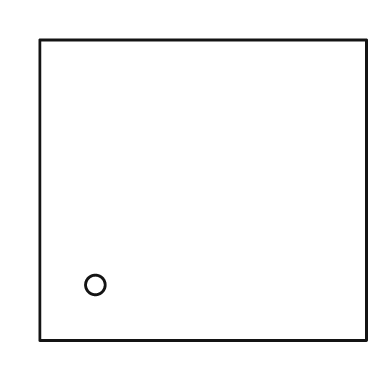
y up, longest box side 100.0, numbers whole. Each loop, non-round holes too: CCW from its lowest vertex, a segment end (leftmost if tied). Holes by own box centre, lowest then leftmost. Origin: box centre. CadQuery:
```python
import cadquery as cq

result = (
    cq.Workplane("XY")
    .moveTo(-50.0, -46.0)
    .lineTo(50.0, -46.0)
    .lineTo(50.0, 46.0)
    .lineTo(-50.0, 46.0)
    .close()
    .moveTo(-33.0, -29.0)
    .circle(3.0)
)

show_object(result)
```